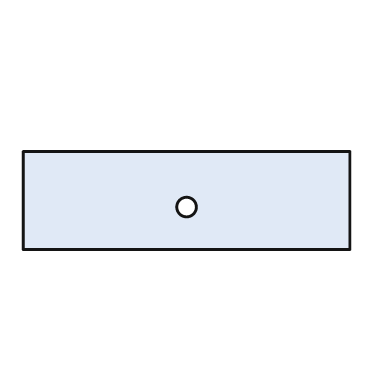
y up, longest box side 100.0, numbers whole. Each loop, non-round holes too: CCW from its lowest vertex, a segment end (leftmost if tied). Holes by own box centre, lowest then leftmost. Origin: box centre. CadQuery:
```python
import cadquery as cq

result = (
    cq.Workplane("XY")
    .moveTo(-50.0, -15.0)
    .lineTo(50.0, -15.0)
    .lineTo(50.0, 15.0)
    .lineTo(-50.0, 15.0)
    .close()
    .moveTo(0.0, -2.0)
    .circle(3.0)
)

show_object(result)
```